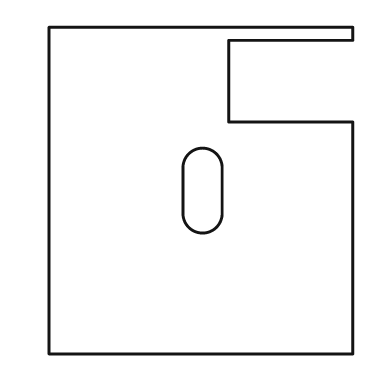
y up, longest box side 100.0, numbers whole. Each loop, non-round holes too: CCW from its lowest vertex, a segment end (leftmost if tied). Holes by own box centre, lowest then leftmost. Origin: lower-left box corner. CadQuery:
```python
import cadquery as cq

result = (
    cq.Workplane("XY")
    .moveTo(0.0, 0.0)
    .lineTo(93.0, 0.0)
    .lineTo(93.0, 71.0)
    .lineTo(55.0, 71.0)
    .lineTo(55.0, 96.0)
    .lineTo(93.0, 96.0)
    .lineTo(93.0, 100.0)
    .lineTo(0.0, 100.0)
    .close()
    .moveTo(41.0, 43.0)
    .threePointArc((47.0, 37.0), (53.0, 43.0))
    .lineTo(53.0, 57.0)
    .threePointArc((47.0, 63.0), (41.0, 57.0))
    .close()
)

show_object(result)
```